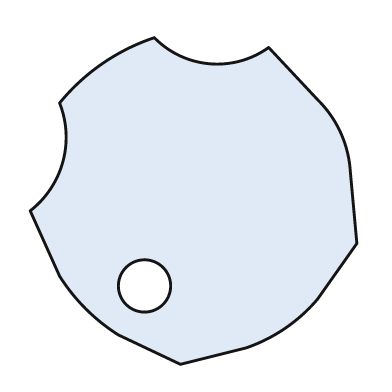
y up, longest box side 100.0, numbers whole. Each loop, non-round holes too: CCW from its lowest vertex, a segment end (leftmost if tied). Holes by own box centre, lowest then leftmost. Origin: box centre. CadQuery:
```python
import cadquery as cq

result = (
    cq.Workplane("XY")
    .moveTo(-4.0, -50.0)
    .lineTo(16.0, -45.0)
    .threePointArc((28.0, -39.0), (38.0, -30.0))
    .lineTo(50.0, -13.0)
    .lineTo(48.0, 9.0)
    .threePointArc((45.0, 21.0), (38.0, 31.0))
    .lineTo(23.0, 47.0)
    .threePointArc((5.0, 42.0), (-12.0, 50.0))
    .threePointArc((-28.0, 42.0), (-41.0, 30.0))
    .threePointArc((-40.0, 12.0), (-50.0, -3.0))
    .lineTo(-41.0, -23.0)
    .threePointArc((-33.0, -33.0), (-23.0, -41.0))
    .close()
    .moveTo(-15.0, -26.0)
    .circle(8.0)
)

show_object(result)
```